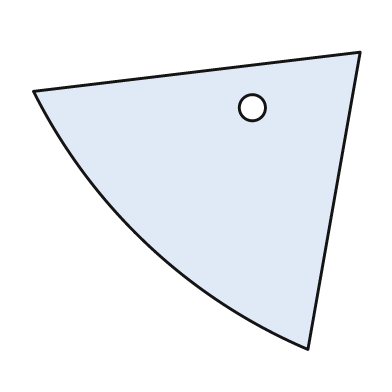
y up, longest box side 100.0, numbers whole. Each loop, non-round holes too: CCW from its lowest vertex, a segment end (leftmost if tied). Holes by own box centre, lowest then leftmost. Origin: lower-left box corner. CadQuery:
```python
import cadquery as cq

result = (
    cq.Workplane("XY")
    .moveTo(84.0, 0.0)
    .lineTo(100.0, 91.0)
    .lineTo(0.0, 79.0)
    .threePointArc((35.0, 32.0), (84.0, 0.0))
    .close()
    .moveTo(67.0, 74.0)
    .circle(4.0)
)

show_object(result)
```